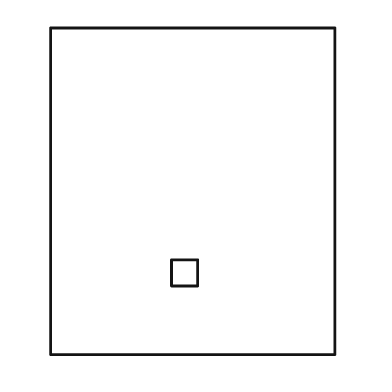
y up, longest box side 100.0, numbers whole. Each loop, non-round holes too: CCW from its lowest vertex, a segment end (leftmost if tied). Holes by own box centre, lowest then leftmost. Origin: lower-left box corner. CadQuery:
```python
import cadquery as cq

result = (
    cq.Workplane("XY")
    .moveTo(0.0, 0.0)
    .lineTo(87.0, 0.0)
    .lineTo(87.0, 100.0)
    .lineTo(0.0, 100.0)
    .close()
    .moveTo(37.0, 21.0)
    .lineTo(45.0, 21.0)
    .lineTo(45.0, 29.0)
    .lineTo(37.0, 29.0)
    .close()
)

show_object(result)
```